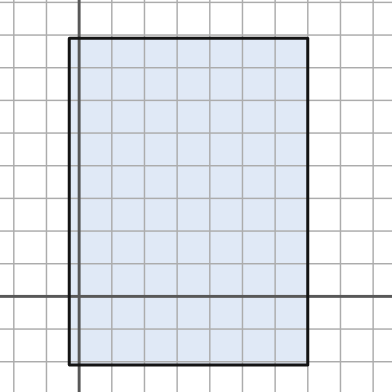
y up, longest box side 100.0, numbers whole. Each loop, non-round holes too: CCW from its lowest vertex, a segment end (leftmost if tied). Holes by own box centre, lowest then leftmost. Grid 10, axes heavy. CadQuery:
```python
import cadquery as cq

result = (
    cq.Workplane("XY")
    .moveTo(-3.0, -21.0)
    .lineTo(70.0, -21.0)
    .lineTo(70.0, 79.0)
    .lineTo(-3.0, 79.0)
    .close()
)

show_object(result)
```